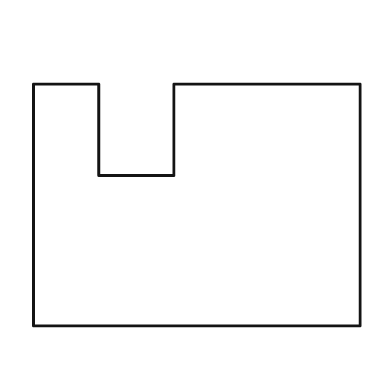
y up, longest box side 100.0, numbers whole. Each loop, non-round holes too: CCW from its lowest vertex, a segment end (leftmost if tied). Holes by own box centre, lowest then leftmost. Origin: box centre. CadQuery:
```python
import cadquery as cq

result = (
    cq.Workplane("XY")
    .moveTo(-50.0, -37.0)
    .lineTo(50.0, -37.0)
    .lineTo(50.0, 37.0)
    .lineTo(-7.0, 37.0)
    .lineTo(-7.0, 9.0)
    .lineTo(-30.0, 9.0)
    .lineTo(-30.0, 37.0)
    .lineTo(-50.0, 37.0)
    .close()
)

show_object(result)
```